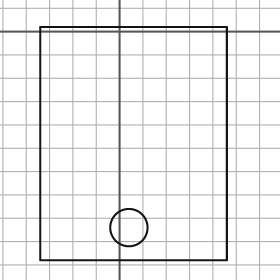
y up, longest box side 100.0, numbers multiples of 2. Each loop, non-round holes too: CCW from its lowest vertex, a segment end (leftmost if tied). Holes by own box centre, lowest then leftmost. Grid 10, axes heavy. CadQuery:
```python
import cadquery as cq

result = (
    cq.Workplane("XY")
    .moveTo(-34.0, -98.0)
    .lineTo(46.0, -98.0)
    .lineTo(46.0, 2.0)
    .lineTo(-34.0, 2.0)
    .close()
    .moveTo(4.0, -84.0)
    .circle(8.0)
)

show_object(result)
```